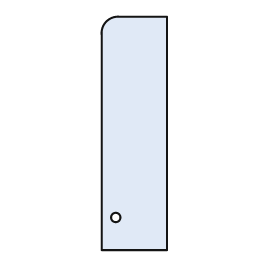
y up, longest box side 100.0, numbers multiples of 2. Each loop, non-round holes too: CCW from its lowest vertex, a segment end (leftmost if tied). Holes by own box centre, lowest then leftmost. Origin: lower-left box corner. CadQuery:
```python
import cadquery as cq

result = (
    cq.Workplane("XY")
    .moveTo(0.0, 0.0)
    .lineTo(28.0, 0.0)
    .lineTo(28.0, 100.0)
    .lineTo(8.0, 100.0)
    .threePointArc((2.0, 98.0), (0.0, 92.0))
    .close()
    .moveTo(6.0, 14.0)
    .circle(2.0)
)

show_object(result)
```